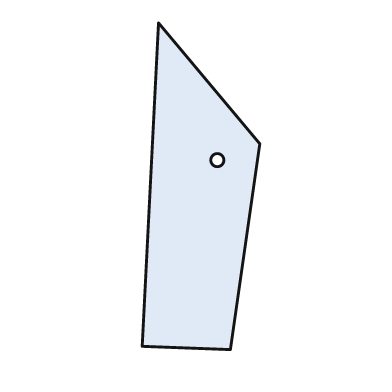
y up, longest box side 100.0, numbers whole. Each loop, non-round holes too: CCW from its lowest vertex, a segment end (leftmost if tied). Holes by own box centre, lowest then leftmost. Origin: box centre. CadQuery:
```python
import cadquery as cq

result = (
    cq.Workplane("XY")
    .moveTo(9.0, -50.0)
    .lineTo(18.0, 13.0)
    .lineTo(-13.0, 50.0)
    .lineTo(-18.0, -49.0)
    .close()
    .moveTo(5.0, 8.0)
    .circle(2.0)
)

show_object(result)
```